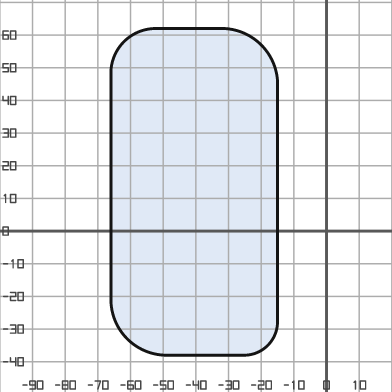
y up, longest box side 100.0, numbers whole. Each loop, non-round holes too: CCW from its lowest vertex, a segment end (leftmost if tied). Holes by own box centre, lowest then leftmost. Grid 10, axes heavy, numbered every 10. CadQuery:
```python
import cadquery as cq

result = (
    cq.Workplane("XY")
    .moveTo(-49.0, -38.0)
    .lineTo(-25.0, -38.0)
    .threePointArc((-18.0, -35.0), (-15.0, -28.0))
    .lineTo(-15.0, 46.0)
    .threePointArc((-20.0, 57.0), (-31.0, 62.0))
    .lineTo(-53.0, 62.0)
    .threePointArc((-62.0, 58.0), (-66.0, 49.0))
    .lineTo(-66.0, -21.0)
    .threePointArc((-61.0, -33.0), (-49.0, -38.0))
    .close()
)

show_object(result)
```